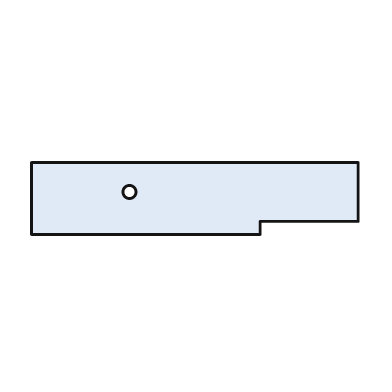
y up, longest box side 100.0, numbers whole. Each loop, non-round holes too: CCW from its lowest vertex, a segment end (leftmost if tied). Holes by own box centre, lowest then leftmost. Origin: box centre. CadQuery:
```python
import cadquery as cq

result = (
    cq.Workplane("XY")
    .moveTo(-50.0, -11.0)
    .lineTo(20.0, -11.0)
    .lineTo(20.0, -7.0)
    .lineTo(50.0, -7.0)
    .lineTo(50.0, 11.0)
    .lineTo(-50.0, 11.0)
    .close()
    .moveTo(-20.0, 2.0)
    .circle(2.0)
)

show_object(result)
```